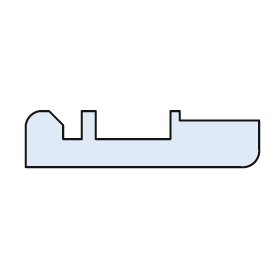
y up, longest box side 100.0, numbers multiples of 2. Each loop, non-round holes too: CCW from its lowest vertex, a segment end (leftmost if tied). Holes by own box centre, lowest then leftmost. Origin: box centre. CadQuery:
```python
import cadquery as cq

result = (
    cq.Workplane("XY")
    .moveTo(-50.0, -12.0)
    .lineTo(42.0, -12.0)
    .threePointArc((48.0, -10.0), (50.0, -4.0))
    .lineTo(50.0, 8.0)
    .lineTo(16.0, 8.0)
    .lineTo(16.0, 12.0)
    .lineTo(12.0, 12.0)
    .lineTo(12.0, 0.0)
    .lineTo(-20.0, 0.0)
    .lineTo(-20.0, 12.0)
    .lineTo(-26.0, 12.0)
    .lineTo(-26.0, 0.0)
    .lineTo(-34.0, 0.0)
    .lineTo(-34.0, 6.0)
    .lineTo(-40.0, 12.0)
    .lineTo(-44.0, 12.0)
    .threePointArc((-48.0, 10.0), (-50.0, 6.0))
    .close()
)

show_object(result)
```